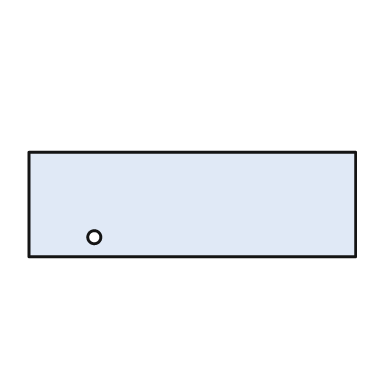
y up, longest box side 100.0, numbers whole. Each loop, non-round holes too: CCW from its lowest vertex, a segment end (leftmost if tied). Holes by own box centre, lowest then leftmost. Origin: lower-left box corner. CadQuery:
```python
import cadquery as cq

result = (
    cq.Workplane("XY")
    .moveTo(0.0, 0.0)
    .lineTo(100.0, 0.0)
    .lineTo(100.0, 32.0)
    .lineTo(0.0, 32.0)
    .close()
    .moveTo(20.0, 6.0)
    .circle(2.0)
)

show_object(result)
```